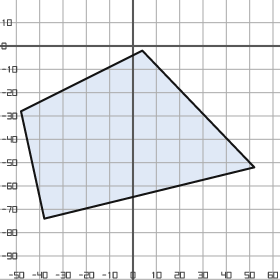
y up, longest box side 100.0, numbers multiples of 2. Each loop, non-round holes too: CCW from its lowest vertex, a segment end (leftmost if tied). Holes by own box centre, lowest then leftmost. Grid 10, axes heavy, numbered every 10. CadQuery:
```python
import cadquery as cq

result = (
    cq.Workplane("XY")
    .moveTo(-38.0, -74.0)
    .lineTo(52.0, -52.0)
    .lineTo(4.0, -2.0)
    .lineTo(-48.0, -28.0)
    .close()
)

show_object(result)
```